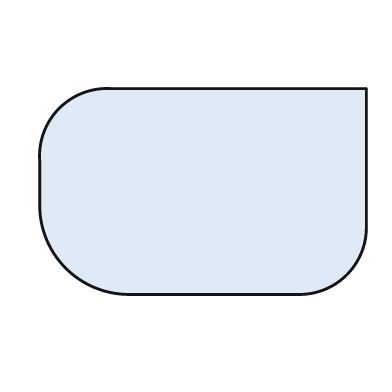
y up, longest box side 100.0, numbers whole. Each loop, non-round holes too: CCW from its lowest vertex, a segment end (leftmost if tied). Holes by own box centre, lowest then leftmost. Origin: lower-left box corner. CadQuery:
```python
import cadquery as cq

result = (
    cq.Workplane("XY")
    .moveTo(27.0, 0.0)
    .lineTo(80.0, 0.0)
    .threePointArc((94.0, 6.0), (100.0, 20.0))
    .lineTo(100.0, 63.0)
    .lineTo(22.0, 63.0)
    .threePointArc((6.0, 57.0), (0.0, 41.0))
    .lineTo(0.0, 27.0)
    .threePointArc((8.0, 8.0), (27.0, 0.0))
    .close()
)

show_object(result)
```